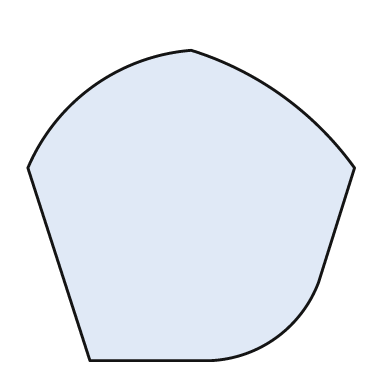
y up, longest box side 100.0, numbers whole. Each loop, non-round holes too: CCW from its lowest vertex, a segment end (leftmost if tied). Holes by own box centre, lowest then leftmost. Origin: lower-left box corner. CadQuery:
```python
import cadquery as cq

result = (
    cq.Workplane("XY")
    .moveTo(19.0, 0.0)
    .lineTo(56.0, 0.0)
    .threePointArc((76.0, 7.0), (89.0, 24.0))
    .lineTo(100.0, 59.0)
    .threePointArc((78.0, 81.0), (50.0, 95.0))
    .threePointArc((20.0, 84.0), (0.0, 59.0))
    .close()
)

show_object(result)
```